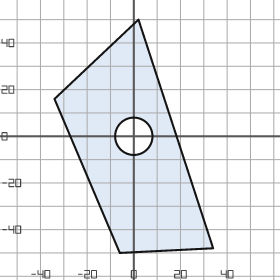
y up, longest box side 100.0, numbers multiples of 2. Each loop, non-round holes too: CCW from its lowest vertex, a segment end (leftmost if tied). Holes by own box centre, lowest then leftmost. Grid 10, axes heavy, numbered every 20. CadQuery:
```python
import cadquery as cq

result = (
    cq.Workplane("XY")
    .moveTo(-6.0, -50.0)
    .lineTo(34.0, -48.0)
    .lineTo(2.0, 50.0)
    .lineTo(-34.0, 16.0)
    .close()
    .moveTo(0.0, 0.0)
    .circle(8.0)
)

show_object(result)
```